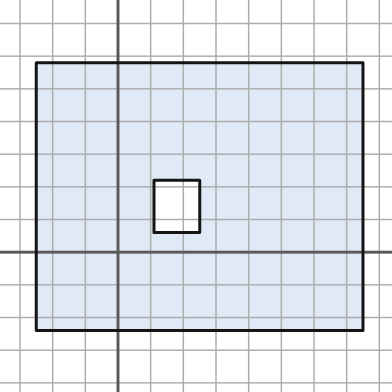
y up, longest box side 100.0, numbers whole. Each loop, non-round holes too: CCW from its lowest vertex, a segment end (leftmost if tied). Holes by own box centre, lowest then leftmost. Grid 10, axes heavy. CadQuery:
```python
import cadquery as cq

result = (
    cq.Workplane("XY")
    .moveTo(-25.0, -24.0)
    .lineTo(75.0, -24.0)
    .lineTo(75.0, 58.0)
    .lineTo(-25.0, 58.0)
    .close()
    .moveTo(11.0, 6.0)
    .lineTo(25.0, 6.0)
    .lineTo(25.0, 22.0)
    .lineTo(11.0, 22.0)
    .close()
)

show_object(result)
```